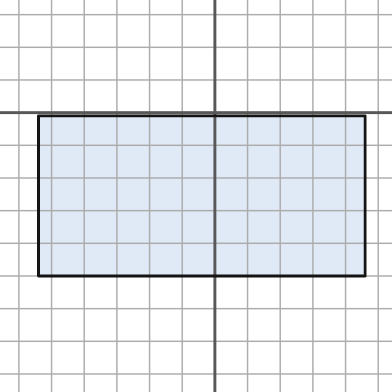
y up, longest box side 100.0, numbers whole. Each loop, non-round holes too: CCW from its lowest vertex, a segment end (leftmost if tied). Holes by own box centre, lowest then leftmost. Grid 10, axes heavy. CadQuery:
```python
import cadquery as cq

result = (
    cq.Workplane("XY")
    .moveTo(-54.0, -50.0)
    .lineTo(46.0, -50.0)
    .lineTo(46.0, -1.0)
    .lineTo(-54.0, -1.0)
    .close()
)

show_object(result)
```